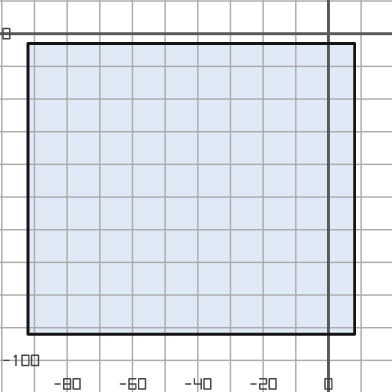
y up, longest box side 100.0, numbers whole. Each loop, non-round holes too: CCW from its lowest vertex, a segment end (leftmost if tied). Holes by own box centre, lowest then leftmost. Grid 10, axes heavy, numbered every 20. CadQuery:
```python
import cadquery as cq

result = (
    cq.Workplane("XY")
    .moveTo(-92.0, -92.0)
    .lineTo(8.0, -92.0)
    .lineTo(8.0, -3.0)
    .lineTo(-92.0, -3.0)
    .close()
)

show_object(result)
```